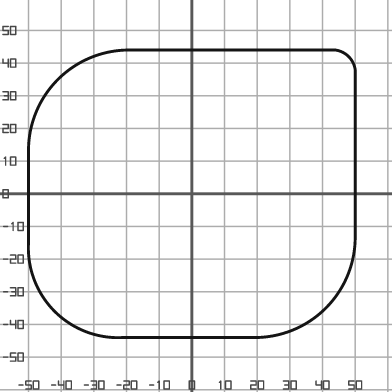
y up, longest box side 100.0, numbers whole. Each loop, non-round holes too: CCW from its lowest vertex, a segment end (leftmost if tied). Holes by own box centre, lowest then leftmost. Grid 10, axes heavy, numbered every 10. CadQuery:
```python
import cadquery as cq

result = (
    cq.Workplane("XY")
    .moveTo(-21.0, -44.0)
    .lineTo(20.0, -44.0)
    .threePointArc((41.0, -35.0), (50.0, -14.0))
    .lineTo(50.0, 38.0)
    .threePointArc((48.0, 42.0), (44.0, 44.0))
    .lineTo(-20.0, 44.0)
    .threePointArc((-41.0, 35.0), (-50.0, 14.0))
    .lineTo(-50.0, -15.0)
    .threePointArc((-42.0, -36.0), (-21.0, -44.0))
    .close()
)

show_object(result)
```